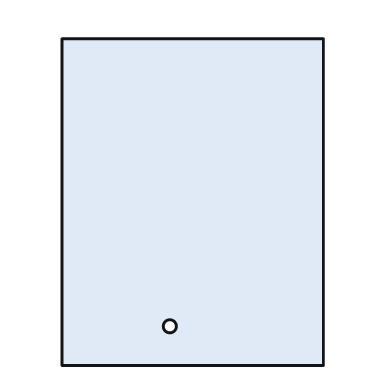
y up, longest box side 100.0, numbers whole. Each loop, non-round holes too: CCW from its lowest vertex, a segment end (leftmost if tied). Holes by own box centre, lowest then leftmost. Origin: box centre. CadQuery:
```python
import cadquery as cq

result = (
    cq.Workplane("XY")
    .moveTo(-40.0, -50.0)
    .lineTo(40.0, -50.0)
    .lineTo(40.0, 50.0)
    .lineTo(-40.0, 50.0)
    .close()
    .moveTo(-7.0, -38.0)
    .circle(2.0)
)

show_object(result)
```